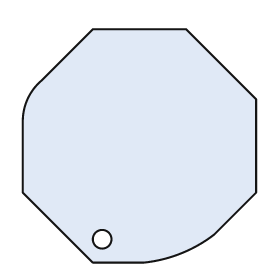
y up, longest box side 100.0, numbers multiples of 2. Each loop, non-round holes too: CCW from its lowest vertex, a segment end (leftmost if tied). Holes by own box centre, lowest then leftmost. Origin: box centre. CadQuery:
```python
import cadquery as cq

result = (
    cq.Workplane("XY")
    .moveTo(-20.0, -50.0)
    .lineTo(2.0, -50.0)
    .threePointArc((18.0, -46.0), (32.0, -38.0))
    .lineTo(50.0, -20.0)
    .lineTo(50.0, 20.0)
    .lineTo(20.0, 50.0)
    .lineTo(-20.0, 50.0)
    .lineTo(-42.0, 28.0)
    .threePointArc((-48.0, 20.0), (-50.0, 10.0))
    .lineTo(-50.0, -20.0)
    .close()
    .moveTo(-16.0, -40.0)
    .circle(4.0)
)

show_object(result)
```